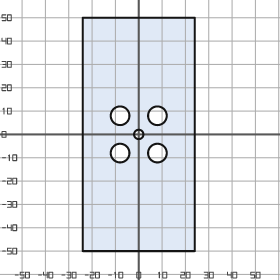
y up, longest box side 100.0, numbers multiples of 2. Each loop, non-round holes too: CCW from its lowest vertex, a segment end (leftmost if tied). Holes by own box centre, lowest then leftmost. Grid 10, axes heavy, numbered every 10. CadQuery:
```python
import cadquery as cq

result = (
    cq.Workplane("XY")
    .moveTo(-24.0, -50.0)
    .lineTo(24.0, -50.0)
    .lineTo(24.0, 50.0)
    .lineTo(-24.0, 50.0)
    .close()
    .moveTo(-8.0, -8.0)
    .circle(4.0)
    .moveTo(8.0, -8.0)
    .circle(4.0)
    .moveTo(0.0, 0.0)
    .circle(2.0)
    .moveTo(-8.0, 8.0)
    .circle(4.0)
    .moveTo(8.0, 8.0)
    .circle(4.0)
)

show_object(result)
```